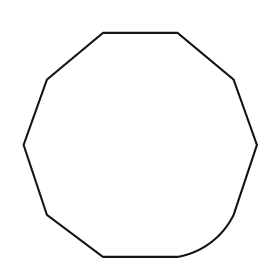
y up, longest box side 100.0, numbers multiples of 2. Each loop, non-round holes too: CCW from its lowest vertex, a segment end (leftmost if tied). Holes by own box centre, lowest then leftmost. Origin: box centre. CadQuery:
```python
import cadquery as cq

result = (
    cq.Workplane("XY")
    .moveTo(-16.0, -48.0)
    .lineTo(16.0, -48.0)
    .threePointArc((30.0, -42.0), (40.0, -30.0))
    .lineTo(50.0, 0.0)
    .lineTo(40.0, 28.0)
    .lineTo(16.0, 48.0)
    .lineTo(-16.0, 48.0)
    .lineTo(-40.0, 28.0)
    .lineTo(-50.0, 0.0)
    .lineTo(-40.0, -30.0)
    .close()
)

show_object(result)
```